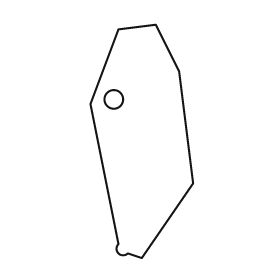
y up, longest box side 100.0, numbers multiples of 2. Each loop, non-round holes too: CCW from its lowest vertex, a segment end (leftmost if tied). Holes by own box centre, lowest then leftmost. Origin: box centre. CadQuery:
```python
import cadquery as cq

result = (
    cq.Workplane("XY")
    .moveTo(0.0, -50.0)
    .lineTo(22.0, -18.0)
    .lineTo(16.0, 30.0)
    .lineTo(6.0, 50.0)
    .lineTo(-10.0, 48.0)
    .lineTo(-22.0, 16.0)
    .lineTo(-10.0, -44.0)
    .threePointArc((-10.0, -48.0), (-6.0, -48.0))
    .close()
    .moveTo(-12.0, 18.0)
    .circle(4.0)
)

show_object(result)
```